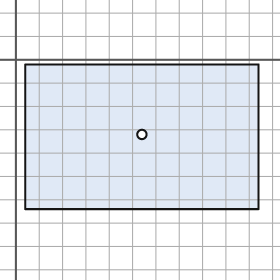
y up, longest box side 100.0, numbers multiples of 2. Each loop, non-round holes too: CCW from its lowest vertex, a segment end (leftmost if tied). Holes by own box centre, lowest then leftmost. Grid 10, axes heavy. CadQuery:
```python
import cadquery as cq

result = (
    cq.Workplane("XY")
    .moveTo(4.0, -64.0)
    .lineTo(104.0, -64.0)
    .lineTo(104.0, -2.0)
    .lineTo(4.0, -2.0)
    .close()
    .moveTo(54.0, -32.0)
    .circle(2.0)
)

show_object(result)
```